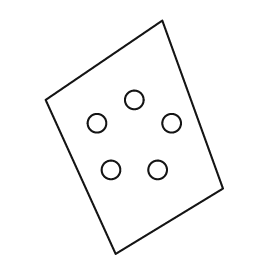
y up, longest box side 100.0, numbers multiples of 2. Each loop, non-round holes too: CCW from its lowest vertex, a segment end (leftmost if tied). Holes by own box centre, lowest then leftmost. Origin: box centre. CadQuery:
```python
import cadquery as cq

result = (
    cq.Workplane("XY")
    .moveTo(-8.0, -50.0)
    .lineTo(38.0, -22.0)
    .lineTo(12.0, 50.0)
    .lineTo(-38.0, 16.0)
    .close()
    .moveTo(-10.0, -14.0)
    .circle(4.0)
    .moveTo(10.0, -14.0)
    .circle(4.0)
    .moveTo(-16.0, 6.0)
    .circle(4.0)
    .moveTo(16.0, 6.0)
    .circle(4.0)
    .moveTo(0.0, 16.0)
    .circle(4.0)
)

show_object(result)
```